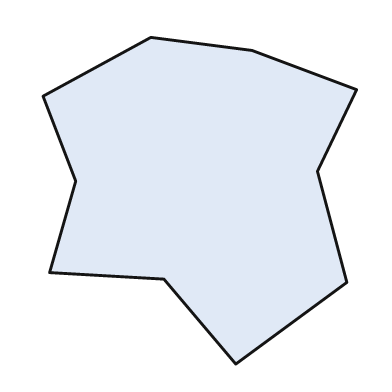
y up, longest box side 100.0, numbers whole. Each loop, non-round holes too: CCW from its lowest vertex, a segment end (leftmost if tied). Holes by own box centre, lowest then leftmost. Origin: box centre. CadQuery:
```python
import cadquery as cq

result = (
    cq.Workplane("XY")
    .moveTo(11.0, -50.0)
    .lineTo(45.0, -25.0)
    .lineTo(36.0, 9.0)
    .lineTo(48.0, 34.0)
    .lineTo(16.0, 46.0)
    .lineTo(-15.0, 50.0)
    .lineTo(-48.0, 32.0)
    .lineTo(-38.0, 6.0)
    .lineTo(-46.0, -22.0)
    .lineTo(-11.0, -24.0)
    .close()
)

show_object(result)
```